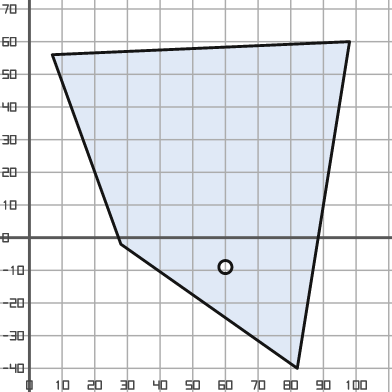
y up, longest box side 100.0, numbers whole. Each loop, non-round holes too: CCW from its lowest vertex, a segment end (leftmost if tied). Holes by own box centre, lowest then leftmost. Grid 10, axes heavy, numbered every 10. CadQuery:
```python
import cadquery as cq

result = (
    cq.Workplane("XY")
    .moveTo(82.0, -40.0)
    .lineTo(98.0, 60.0)
    .lineTo(7.0, 56.0)
    .lineTo(28.0, -2.0)
    .close()
    .moveTo(60.0, -9.0)
    .circle(2.0)
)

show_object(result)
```